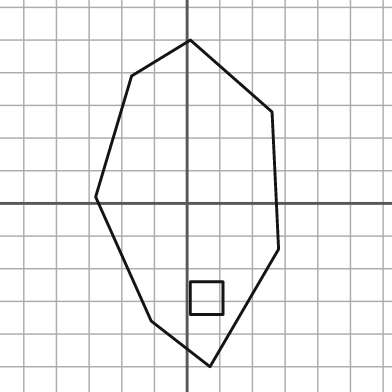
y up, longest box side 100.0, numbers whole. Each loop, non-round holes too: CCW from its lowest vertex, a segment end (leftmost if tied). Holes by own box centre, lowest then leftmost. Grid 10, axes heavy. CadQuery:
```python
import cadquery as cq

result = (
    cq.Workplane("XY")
    .moveTo(7.0, -50.0)
    .lineTo(28.0, -14.0)
    .lineTo(26.0, 28.0)
    .lineTo(1.0, 50.0)
    .lineTo(-17.0, 39.0)
    .lineTo(-28.0, 2.0)
    .lineTo(-11.0, -36.0)
    .close()
    .moveTo(1.0, -34.0)
    .lineTo(11.0, -34.0)
    .lineTo(11.0, -24.0)
    .lineTo(1.0, -24.0)
    .close()
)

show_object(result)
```